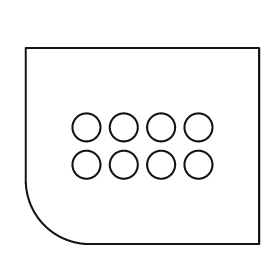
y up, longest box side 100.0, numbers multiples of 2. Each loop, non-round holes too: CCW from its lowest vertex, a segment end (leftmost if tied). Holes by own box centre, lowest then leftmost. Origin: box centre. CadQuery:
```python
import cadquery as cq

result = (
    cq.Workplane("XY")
    .moveTo(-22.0, -42.0)
    .lineTo(50.0, -42.0)
    .lineTo(50.0, 42.0)
    .lineTo(-50.0, 42.0)
    .lineTo(-50.0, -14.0)
    .threePointArc((-42.0, -34.0), (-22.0, -42.0))
    .close()
    .moveTo(-24.0, -8.0)
    .circle(6.0)
    .moveTo(-8.0, -8.0)
    .circle(6.0)
    .moveTo(8.0, -8.0)
    .circle(6.0)
    .moveTo(24.0, -8.0)
    .circle(6.0)
    .moveTo(-24.0, 8.0)
    .circle(6.0)
    .moveTo(-8.0, 8.0)
    .circle(6.0)
    .moveTo(8.0, 8.0)
    .circle(6.0)
    .moveTo(24.0, 8.0)
    .circle(6.0)
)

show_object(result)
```